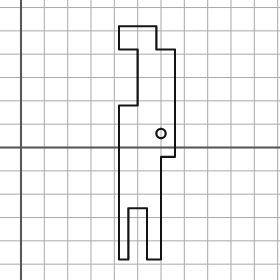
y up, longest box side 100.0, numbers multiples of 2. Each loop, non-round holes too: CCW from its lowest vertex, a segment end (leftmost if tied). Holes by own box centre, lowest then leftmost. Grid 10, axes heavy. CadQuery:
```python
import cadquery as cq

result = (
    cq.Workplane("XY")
    .moveTo(42.0, -48.0)
    .lineTo(46.0, -48.0)
    .lineTo(46.0, -26.0)
    .lineTo(54.0, -26.0)
    .lineTo(54.0, -48.0)
    .lineTo(60.0, -48.0)
    .lineTo(60.0, -4.0)
    .lineTo(66.0, -4.0)
    .lineTo(66.0, 42.0)
    .lineTo(58.0, 42.0)
    .lineTo(58.0, 52.0)
    .lineTo(42.0, 52.0)
    .lineTo(42.0, 42.0)
    .lineTo(50.0, 42.0)
    .lineTo(50.0, 18.0)
    .lineTo(42.0, 18.0)
    .close()
    .moveTo(60.0, 6.0)
    .circle(2.0)
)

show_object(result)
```